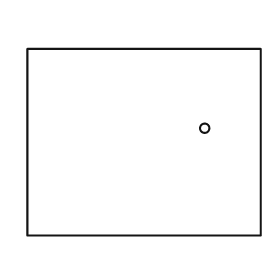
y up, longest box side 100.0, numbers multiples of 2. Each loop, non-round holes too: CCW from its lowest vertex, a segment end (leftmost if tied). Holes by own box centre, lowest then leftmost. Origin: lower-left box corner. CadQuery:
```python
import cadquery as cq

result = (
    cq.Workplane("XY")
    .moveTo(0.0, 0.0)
    .lineTo(100.0, 0.0)
    .lineTo(100.0, 80.0)
    .lineTo(0.0, 80.0)
    .close()
    .moveTo(76.0, 46.0)
    .circle(2.0)
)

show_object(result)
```